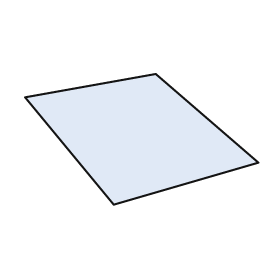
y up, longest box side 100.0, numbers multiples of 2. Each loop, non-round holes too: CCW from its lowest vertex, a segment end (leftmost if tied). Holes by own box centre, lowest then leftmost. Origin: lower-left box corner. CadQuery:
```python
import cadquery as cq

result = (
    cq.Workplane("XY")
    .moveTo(38.0, 0.0)
    .lineTo(100.0, 18.0)
    .lineTo(56.0, 56.0)
    .lineTo(0.0, 46.0)
    .close()
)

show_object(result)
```